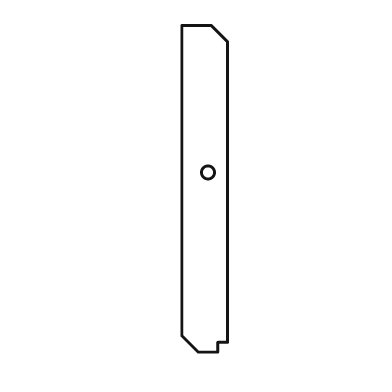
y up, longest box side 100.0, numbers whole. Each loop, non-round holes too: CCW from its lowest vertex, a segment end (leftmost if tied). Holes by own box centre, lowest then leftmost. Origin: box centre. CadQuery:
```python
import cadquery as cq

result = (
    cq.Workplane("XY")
    .moveTo(-2.0, -50.0)
    .lineTo(4.0, -50.0)
    .lineTo(4.0, -47.0)
    .lineTo(7.0, -47.0)
    .lineTo(7.0, 45.0)
    .lineTo(2.0, 50.0)
    .lineTo(-7.0, 50.0)
    .lineTo(-7.0, -45.0)
    .close()
    .moveTo(1.0, 5.0)
    .circle(2.0)
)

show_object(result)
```